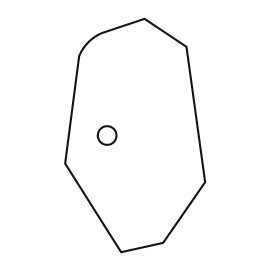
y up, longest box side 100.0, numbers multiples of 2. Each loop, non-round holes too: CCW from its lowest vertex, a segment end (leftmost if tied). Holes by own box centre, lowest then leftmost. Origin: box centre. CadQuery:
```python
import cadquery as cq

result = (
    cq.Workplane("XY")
    .moveTo(-6.0, -50.0)
    .lineTo(12.0, -46.0)
    .lineTo(30.0, -20.0)
    .lineTo(22.0, 38.0)
    .lineTo(4.0, 50.0)
    .lineTo(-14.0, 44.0)
    .threePointArc((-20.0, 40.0), (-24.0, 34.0))
    .lineTo(-30.0, -12.0)
    .close()
    .moveTo(-12.0, 0.0)
    .circle(4.0)
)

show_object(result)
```